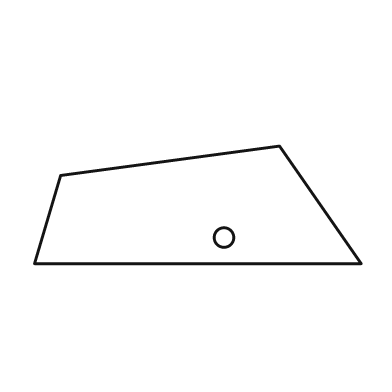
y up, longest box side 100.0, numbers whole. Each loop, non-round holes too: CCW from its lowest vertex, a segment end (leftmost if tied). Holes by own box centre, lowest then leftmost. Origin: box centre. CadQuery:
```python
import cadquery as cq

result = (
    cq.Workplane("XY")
    .moveTo(-50.0, -18.0)
    .lineTo(50.0, -18.0)
    .lineTo(25.0, 18.0)
    .lineTo(-42.0, 9.0)
    .close()
    .moveTo(8.0, -10.0)
    .circle(3.0)
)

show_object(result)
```